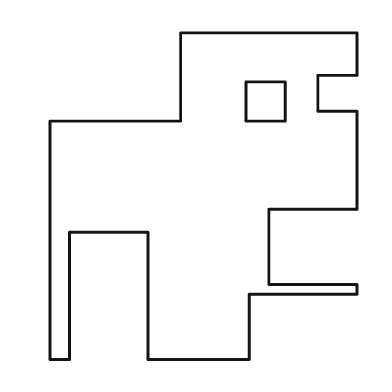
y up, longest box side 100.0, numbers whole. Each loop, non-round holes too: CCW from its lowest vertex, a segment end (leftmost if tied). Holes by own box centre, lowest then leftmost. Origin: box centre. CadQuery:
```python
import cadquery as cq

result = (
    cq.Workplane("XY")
    .moveTo(-47.0, -50.0)
    .lineTo(-41.0, -50.0)
    .lineTo(-41.0, -11.0)
    .lineTo(-17.0, -11.0)
    .lineTo(-17.0, -50.0)
    .lineTo(14.0, -50.0)
    .lineTo(14.0, -30.0)
    .lineTo(47.0, -30.0)
    .lineTo(47.0, -27.0)
    .lineTo(20.0, -27.0)
    .lineTo(20.0, -4.0)
    .lineTo(47.0, -4.0)
    .lineTo(47.0, 26.0)
    .lineTo(35.0, 26.0)
    .lineTo(35.0, 37.0)
    .lineTo(47.0, 37.0)
    .lineTo(47.0, 50.0)
    .lineTo(-7.0, 50.0)
    .lineTo(-7.0, 23.0)
    .lineTo(-47.0, 23.0)
    .close()
    .moveTo(13.0, 23.0)
    .lineTo(25.0, 23.0)
    .lineTo(25.0, 35.0)
    .lineTo(13.0, 35.0)
    .close()
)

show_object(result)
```